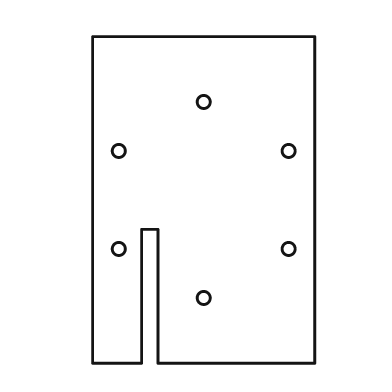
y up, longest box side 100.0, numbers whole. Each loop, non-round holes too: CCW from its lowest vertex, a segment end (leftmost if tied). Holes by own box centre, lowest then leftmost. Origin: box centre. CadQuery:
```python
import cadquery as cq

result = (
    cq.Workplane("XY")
    .moveTo(-34.0, -50.0)
    .lineTo(-19.0, -50.0)
    .lineTo(-19.0, -9.0)
    .lineTo(-14.0, -9.0)
    .lineTo(-14.0, -50.0)
    .lineTo(34.0, -50.0)
    .lineTo(34.0, 50.0)
    .lineTo(-34.0, 50.0)
    .close()
    .moveTo(0.0, -30.0)
    .circle(2.0)
    .moveTo(-26.0, -15.0)
    .circle(2.0)
    .moveTo(26.0, -15.0)
    .circle(2.0)
    .moveTo(-26.0, 15.0)
    .circle(2.0)
    .moveTo(26.0, 15.0)
    .circle(2.0)
    .moveTo(0.0, 30.0)
    .circle(2.0)
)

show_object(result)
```